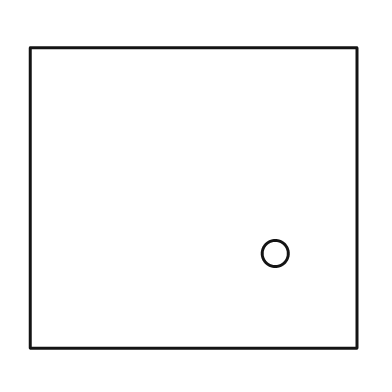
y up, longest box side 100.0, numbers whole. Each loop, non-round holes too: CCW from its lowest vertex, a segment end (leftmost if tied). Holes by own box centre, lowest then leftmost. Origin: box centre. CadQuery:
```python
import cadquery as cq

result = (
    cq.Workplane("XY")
    .moveTo(-50.0, -46.0)
    .lineTo(50.0, -46.0)
    .lineTo(50.0, 46.0)
    .lineTo(-50.0, 46.0)
    .close()
    .moveTo(25.0, -17.0)
    .circle(4.0)
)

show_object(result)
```